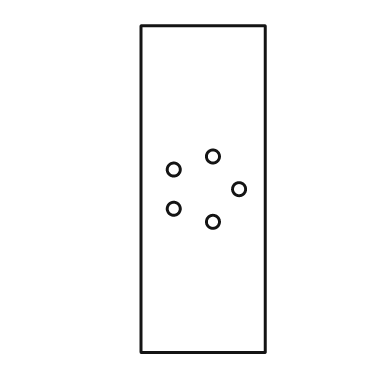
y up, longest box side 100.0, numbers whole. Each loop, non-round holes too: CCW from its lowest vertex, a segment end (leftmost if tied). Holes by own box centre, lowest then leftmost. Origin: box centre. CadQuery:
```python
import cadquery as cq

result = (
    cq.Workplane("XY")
    .moveTo(-19.0, -50.0)
    .lineTo(19.0, -50.0)
    .lineTo(19.0, 50.0)
    .lineTo(-19.0, 50.0)
    .close()
    .moveTo(3.0, -10.0)
    .circle(2.0)
    .moveTo(-9.0, -6.0)
    .circle(2.0)
    .moveTo(11.0, 0.0)
    .circle(2.0)
    .moveTo(-9.0, 6.0)
    .circle(2.0)
    .moveTo(3.0, 10.0)
    .circle(2.0)
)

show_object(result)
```